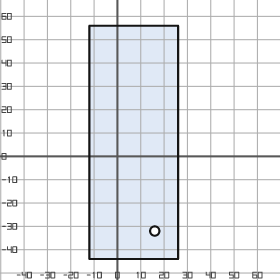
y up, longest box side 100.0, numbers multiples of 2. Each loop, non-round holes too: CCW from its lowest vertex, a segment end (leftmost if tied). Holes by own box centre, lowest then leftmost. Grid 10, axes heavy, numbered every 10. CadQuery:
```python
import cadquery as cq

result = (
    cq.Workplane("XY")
    .moveTo(-12.0, -44.0)
    .lineTo(26.0, -44.0)
    .lineTo(26.0, 56.0)
    .lineTo(-12.0, 56.0)
    .close()
    .moveTo(16.0, -32.0)
    .circle(2.0)
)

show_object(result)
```